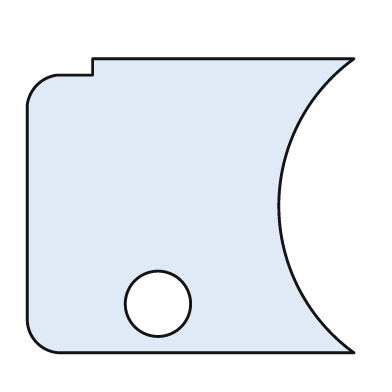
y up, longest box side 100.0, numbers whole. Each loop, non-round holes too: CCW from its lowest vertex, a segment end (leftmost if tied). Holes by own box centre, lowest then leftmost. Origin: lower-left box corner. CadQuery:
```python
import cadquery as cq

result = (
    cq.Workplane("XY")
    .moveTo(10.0, 0.0)
    .lineTo(100.0, 0.0)
    .threePointArc((77.0, 45.0), (100.0, 90.0))
    .lineTo(20.0, 90.0)
    .lineTo(20.0, 85.0)
    .lineTo(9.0, 85.0)
    .threePointArc((3.0, 82.0), (0.0, 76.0))
    .lineTo(0.0, 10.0)
    .threePointArc((3.0, 3.0), (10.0, 0.0))
    .close()
    .moveTo(40.0, 15.0)
    .circle(10.0)
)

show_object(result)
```